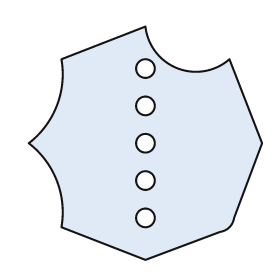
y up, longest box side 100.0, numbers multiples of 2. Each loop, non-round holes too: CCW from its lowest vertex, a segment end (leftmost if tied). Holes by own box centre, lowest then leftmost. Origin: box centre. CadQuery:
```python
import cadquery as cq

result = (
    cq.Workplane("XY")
    .moveTo(0.0, -50.0)
    .lineTo(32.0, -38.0)
    .threePointArc((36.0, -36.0), (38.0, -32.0))
    .lineTo(50.0, 0.0)
    .lineTo(36.0, 36.0)
    .threePointArc((14.0, 32.0), (0.0, 50.0))
    .lineTo(-36.0, 36.0)
    .threePointArc((-38.0, 16.0), (-50.0, 0.0))
    .threePointArc((-38.0, -16.0), (-36.0, -36.0))
    .close()
    .moveTo(0.0, -32.0)
    .circle(4.0)
    .moveTo(0.0, -16.0)
    .circle(4.0)
    .moveTo(0.0, 0.0)
    .circle(4.0)
    .moveTo(0.0, 16.0)
    .circle(4.0)
    .moveTo(0.0, 32.0)
    .circle(4.0)
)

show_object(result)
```